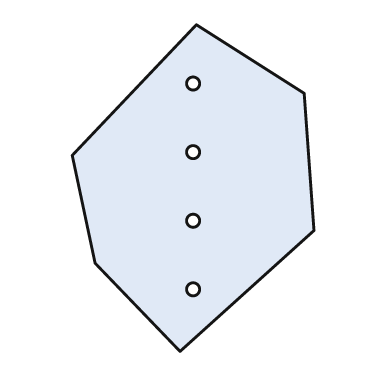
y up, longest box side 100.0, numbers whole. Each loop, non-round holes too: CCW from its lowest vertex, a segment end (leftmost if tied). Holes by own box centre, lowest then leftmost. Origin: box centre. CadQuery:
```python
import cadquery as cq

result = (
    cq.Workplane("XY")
    .moveTo(-4.0, -50.0)
    .lineTo(37.0, -13.0)
    .lineTo(34.0, 29.0)
    .lineTo(1.0, 50.0)
    .lineTo(-37.0, 10.0)
    .lineTo(-30.0, -23.0)
    .close()
    .moveTo(0.0, -31.0)
    .circle(2.0)
    .moveTo(0.0, -10.0)
    .circle(2.0)
    .moveTo(0.0, 11.0)
    .circle(2.0)
    .moveTo(0.0, 32.0)
    .circle(2.0)
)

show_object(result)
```